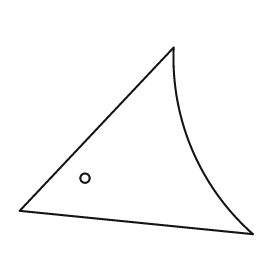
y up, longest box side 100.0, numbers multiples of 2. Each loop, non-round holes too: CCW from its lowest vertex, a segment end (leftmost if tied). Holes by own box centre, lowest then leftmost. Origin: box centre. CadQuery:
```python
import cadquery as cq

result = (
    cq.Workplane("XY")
    .moveTo(50.0, -40.0)
    .threePointArc((24.0, -4.0), (16.0, 40.0))
    .lineTo(-50.0, -30.0)
    .close()
    .moveTo(-22.0, -16.0)
    .circle(2.0)
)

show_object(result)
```